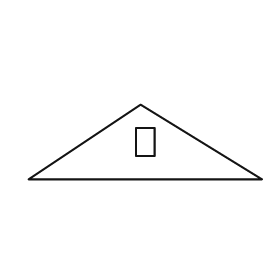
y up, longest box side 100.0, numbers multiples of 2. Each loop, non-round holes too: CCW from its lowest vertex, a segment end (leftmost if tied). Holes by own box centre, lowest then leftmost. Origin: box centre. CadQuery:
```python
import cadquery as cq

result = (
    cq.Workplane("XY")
    .moveTo(-50.0, -16.0)
    .lineTo(50.0, -16.0)
    .lineTo(-2.0, 16.0)
    .close()
    .moveTo(-4.0, -6.0)
    .lineTo(4.0, -6.0)
    .lineTo(4.0, 6.0)
    .lineTo(-4.0, 6.0)
    .close()
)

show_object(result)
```